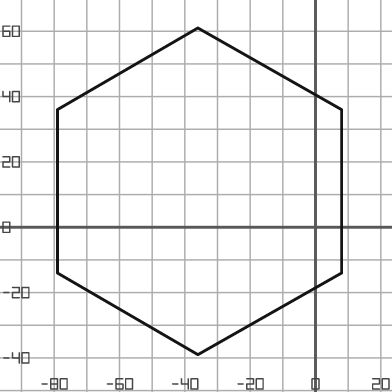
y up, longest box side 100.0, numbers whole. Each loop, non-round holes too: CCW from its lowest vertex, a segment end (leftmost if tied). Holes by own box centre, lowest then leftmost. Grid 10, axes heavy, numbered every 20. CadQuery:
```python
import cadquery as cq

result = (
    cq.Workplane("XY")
    .moveTo(-36.0, -39.0)
    .lineTo(8.0, -14.0)
    .lineTo(8.0, 36.0)
    .lineTo(-36.0, 61.0)
    .lineTo(-79.0, 36.0)
    .lineTo(-79.0, -14.0)
    .close()
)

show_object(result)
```